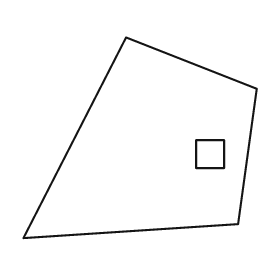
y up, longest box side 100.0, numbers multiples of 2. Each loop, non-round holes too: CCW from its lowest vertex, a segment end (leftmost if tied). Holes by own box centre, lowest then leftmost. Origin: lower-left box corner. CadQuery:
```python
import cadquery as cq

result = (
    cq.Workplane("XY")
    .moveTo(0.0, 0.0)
    .lineTo(92.0, 6.0)
    .lineTo(100.0, 64.0)
    .lineTo(44.0, 86.0)
    .close()
    .moveTo(74.0, 30.0)
    .lineTo(86.0, 30.0)
    .lineTo(86.0, 42.0)
    .lineTo(74.0, 42.0)
    .close()
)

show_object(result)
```